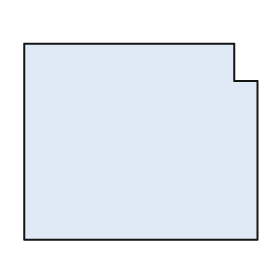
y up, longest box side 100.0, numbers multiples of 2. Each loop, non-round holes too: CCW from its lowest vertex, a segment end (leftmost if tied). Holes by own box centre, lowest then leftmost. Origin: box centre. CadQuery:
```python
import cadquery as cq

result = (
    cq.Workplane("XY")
    .moveTo(-50.0, -42.0)
    .lineTo(50.0, -42.0)
    .lineTo(50.0, 26.0)
    .lineTo(40.0, 26.0)
    .lineTo(40.0, 42.0)
    .lineTo(-50.0, 42.0)
    .close()
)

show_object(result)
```